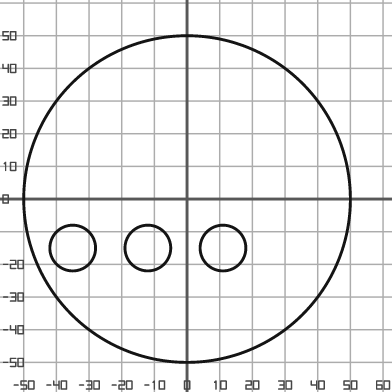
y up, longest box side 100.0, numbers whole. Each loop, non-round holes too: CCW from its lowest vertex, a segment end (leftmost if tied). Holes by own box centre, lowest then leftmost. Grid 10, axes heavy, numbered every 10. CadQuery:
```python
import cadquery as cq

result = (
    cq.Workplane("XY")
    .moveTo(0.0, 0.0)
    .circle(50.0)
    .moveTo(-35.0, -15.0)
    .circle(7.0)
    .moveTo(-12.0, -15.0)
    .circle(7.0)
    .moveTo(11.0, -15.0)
    .circle(7.0)
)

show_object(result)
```